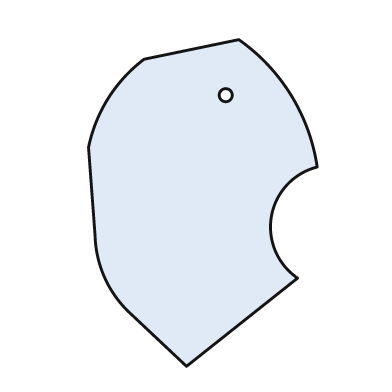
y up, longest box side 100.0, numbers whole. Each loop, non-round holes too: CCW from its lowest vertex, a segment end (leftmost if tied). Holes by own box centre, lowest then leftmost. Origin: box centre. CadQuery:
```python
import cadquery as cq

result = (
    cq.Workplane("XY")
    .moveTo(-5.0, -50.0)
    .lineTo(29.0, -23.0)
    .threePointArc((21.0, -4.0), (35.0, 11.0))
    .threePointArc((27.0, 33.0), (11.0, 50.0))
    .lineTo(-18.0, 44.0)
    .threePointArc((-29.0, 32.0), (-35.0, 17.0))
    .lineTo(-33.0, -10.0)
    .threePointArc((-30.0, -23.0), (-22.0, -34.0))
    .close()
    .moveTo(7.0, 33.0)
    .circle(2.0)
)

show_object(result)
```